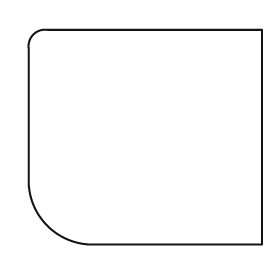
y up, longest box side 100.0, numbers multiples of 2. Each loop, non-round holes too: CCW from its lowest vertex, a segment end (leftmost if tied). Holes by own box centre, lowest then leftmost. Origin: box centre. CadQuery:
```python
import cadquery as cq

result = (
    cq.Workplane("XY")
    .moveTo(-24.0, -46.0)
    .lineTo(50.0, -46.0)
    .lineTo(50.0, 46.0)
    .lineTo(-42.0, 46.0)
    .threePointArc((-48.0, 44.0), (-50.0, 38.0))
    .lineTo(-50.0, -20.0)
    .threePointArc((-42.0, -38.0), (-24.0, -46.0))
    .close()
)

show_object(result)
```